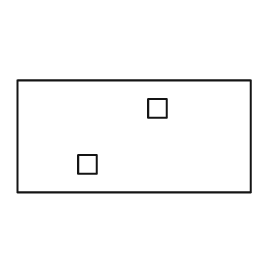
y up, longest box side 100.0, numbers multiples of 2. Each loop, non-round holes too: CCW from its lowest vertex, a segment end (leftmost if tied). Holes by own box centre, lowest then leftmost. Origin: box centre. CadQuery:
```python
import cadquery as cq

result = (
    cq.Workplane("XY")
    .moveTo(-50.0, -24.0)
    .lineTo(50.0, -24.0)
    .lineTo(50.0, 24.0)
    .lineTo(-50.0, 24.0)
    .close()
    .moveTo(-24.0, -16.0)
    .lineTo(-16.0, -16.0)
    .lineTo(-16.0, -8.0)
    .lineTo(-24.0, -8.0)
    .close()
    .moveTo(6.0, 8.0)
    .lineTo(14.0, 8.0)
    .lineTo(14.0, 16.0)
    .lineTo(6.0, 16.0)
    .close()
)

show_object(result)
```